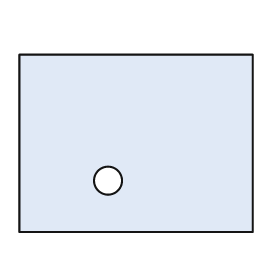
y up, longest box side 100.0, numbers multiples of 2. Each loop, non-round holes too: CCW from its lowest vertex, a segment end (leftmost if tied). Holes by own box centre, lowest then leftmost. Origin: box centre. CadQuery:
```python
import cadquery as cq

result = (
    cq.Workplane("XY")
    .moveTo(-50.0, -38.0)
    .lineTo(50.0, -38.0)
    .lineTo(50.0, 38.0)
    .lineTo(-50.0, 38.0)
    .close()
    .moveTo(-12.0, -16.0)
    .circle(6.0)
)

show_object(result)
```